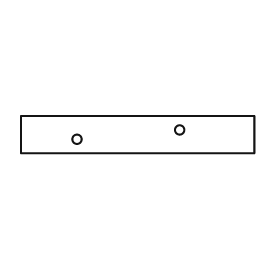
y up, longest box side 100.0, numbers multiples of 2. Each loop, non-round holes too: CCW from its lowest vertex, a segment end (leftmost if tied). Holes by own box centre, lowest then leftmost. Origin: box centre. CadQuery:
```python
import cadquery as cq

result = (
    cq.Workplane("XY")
    .moveTo(-50.0, -8.0)
    .lineTo(50.0, -8.0)
    .lineTo(50.0, 8.0)
    .lineTo(-50.0, 8.0)
    .close()
    .moveTo(-26.0, -2.0)
    .circle(2.0)
    .moveTo(18.0, 2.0)
    .circle(2.0)
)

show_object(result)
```